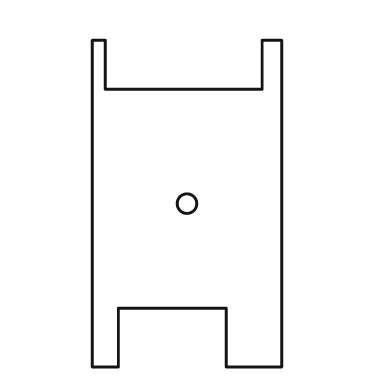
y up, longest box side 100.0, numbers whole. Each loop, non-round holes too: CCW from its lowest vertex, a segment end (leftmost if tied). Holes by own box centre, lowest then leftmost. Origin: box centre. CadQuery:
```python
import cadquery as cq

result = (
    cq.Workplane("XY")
    .moveTo(-29.0, -50.0)
    .lineTo(-21.0, -50.0)
    .lineTo(-21.0, -32.0)
    .lineTo(12.0, -32.0)
    .lineTo(12.0, -50.0)
    .lineTo(29.0, -50.0)
    .lineTo(29.0, 50.0)
    .lineTo(23.0, 50.0)
    .lineTo(23.0, 35.0)
    .lineTo(-25.0, 35.0)
    .lineTo(-25.0, 50.0)
    .lineTo(-29.0, 50.0)
    .close()
    .moveTo(0.0, 0.0)
    .circle(3.0)
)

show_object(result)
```